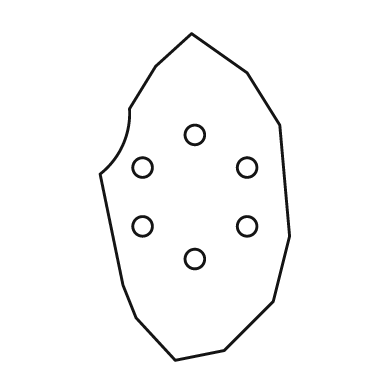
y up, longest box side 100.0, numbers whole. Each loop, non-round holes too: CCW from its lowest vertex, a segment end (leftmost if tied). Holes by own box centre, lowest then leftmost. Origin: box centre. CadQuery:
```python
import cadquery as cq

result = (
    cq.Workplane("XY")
    .moveTo(-6.0, -50.0)
    .lineTo(9.0, -47.0)
    .lineTo(24.0, -32.0)
    .lineTo(29.0, -12.0)
    .lineTo(26.0, 22.0)
    .lineTo(16.0, 38.0)
    .lineTo(-1.0, 50.0)
    .lineTo(-12.0, 40.0)
    .lineTo(-20.0, 27.0)
    .threePointArc((-22.0, 16.0), (-29.0, 7.0))
    .lineTo(-22.0, -27.0)
    .lineTo(-18.0, -37.0)
    .close()
    .moveTo(0.0, -19.0)
    .circle(3.0)
    .moveTo(-16.0, -9.0)
    .circle(3.0)
    .moveTo(16.0, -9.0)
    .circle(3.0)
    .moveTo(-16.0, 9.0)
    .circle(3.0)
    .moveTo(16.0, 9.0)
    .circle(3.0)
    .moveTo(0.0, 19.0)
    .circle(3.0)
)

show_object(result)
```